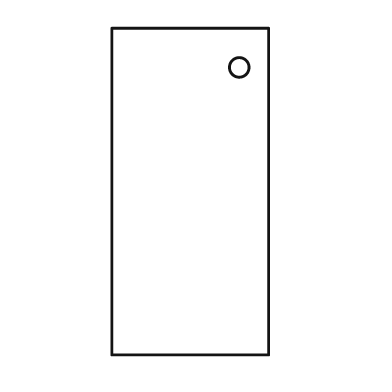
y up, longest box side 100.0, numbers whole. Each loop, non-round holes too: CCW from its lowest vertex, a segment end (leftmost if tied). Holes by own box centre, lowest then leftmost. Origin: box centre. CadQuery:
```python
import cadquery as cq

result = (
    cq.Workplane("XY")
    .moveTo(-24.0, -50.0)
    .lineTo(24.0, -50.0)
    .lineTo(24.0, 50.0)
    .lineTo(-24.0, 50.0)
    .close()
    .moveTo(15.0, 38.0)
    .circle(3.0)
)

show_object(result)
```